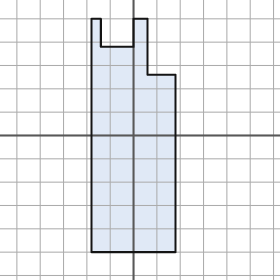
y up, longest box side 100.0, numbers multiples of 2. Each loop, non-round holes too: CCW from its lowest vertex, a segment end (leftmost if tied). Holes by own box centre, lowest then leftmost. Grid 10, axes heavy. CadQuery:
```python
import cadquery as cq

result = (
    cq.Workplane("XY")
    .moveTo(-18.0, -50.0)
    .lineTo(18.0, -50.0)
    .lineTo(18.0, 26.0)
    .lineTo(6.0, 26.0)
    .lineTo(6.0, 50.0)
    .lineTo(0.0, 50.0)
    .lineTo(0.0, 38.0)
    .lineTo(-14.0, 38.0)
    .lineTo(-14.0, 50.0)
    .lineTo(-18.0, 50.0)
    .close()
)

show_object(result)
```